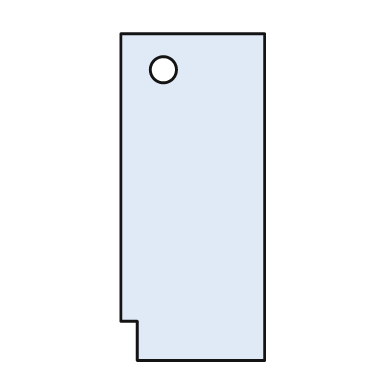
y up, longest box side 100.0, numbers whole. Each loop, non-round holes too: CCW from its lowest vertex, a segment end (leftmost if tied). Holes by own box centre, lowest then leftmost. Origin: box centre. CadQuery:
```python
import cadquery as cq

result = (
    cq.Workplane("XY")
    .moveTo(-17.0, -50.0)
    .lineTo(22.0, -50.0)
    .lineTo(22.0, 50.0)
    .lineTo(-22.0, 50.0)
    .lineTo(-22.0, -38.0)
    .lineTo(-17.0, -38.0)
    .close()
    .moveTo(-9.0, 39.0)
    .circle(4.0)
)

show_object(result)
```